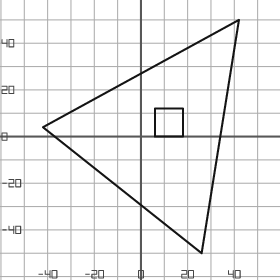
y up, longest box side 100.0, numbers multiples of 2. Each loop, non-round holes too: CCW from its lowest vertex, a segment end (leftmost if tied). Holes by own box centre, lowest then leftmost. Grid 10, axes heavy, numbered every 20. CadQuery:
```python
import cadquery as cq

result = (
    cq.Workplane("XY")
    .moveTo(26.0, -50.0)
    .lineTo(42.0, 50.0)
    .lineTo(-42.0, 4.0)
    .close()
    .moveTo(6.0, 0.0)
    .lineTo(18.0, 0.0)
    .lineTo(18.0, 12.0)
    .lineTo(6.0, 12.0)
    .close()
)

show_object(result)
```